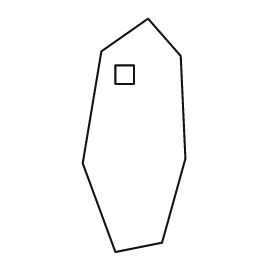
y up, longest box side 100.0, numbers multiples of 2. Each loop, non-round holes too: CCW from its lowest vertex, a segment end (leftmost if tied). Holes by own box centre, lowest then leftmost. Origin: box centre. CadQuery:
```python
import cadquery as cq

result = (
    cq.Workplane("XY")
    .moveTo(-8.0, -50.0)
    .lineTo(12.0, -46.0)
    .lineTo(22.0, -10.0)
    .lineTo(20.0, 34.0)
    .lineTo(6.0, 50.0)
    .lineTo(-14.0, 36.0)
    .lineTo(-22.0, -12.0)
    .close()
    .moveTo(-8.0, 22.0)
    .lineTo(0.0, 22.0)
    .lineTo(0.0, 30.0)
    .lineTo(-8.0, 30.0)
    .close()
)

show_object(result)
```